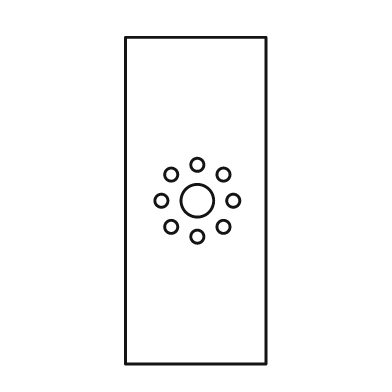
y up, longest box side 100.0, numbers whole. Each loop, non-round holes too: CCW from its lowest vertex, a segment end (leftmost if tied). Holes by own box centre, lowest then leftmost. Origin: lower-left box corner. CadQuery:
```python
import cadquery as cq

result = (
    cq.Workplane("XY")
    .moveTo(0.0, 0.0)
    .lineTo(43.0, 0.0)
    .lineTo(43.0, 100.0)
    .lineTo(0.0, 100.0)
    .close()
    .moveTo(22.0, 39.0)
    .circle(2.0)
    .moveTo(14.0, 42.0)
    .circle(2.0)
    .moveTo(30.0, 42.0)
    .circle(2.0)
    .moveTo(11.0, 50.0)
    .circle(2.0)
    .moveTo(22.0, 50.0)
    .circle(5.0)
    .moveTo(33.0, 50.0)
    .circle(2.0)
    .moveTo(14.0, 58.0)
    .circle(2.0)
    .moveTo(30.0, 58.0)
    .circle(2.0)
    .moveTo(22.0, 61.0)
    .circle(2.0)
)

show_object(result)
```